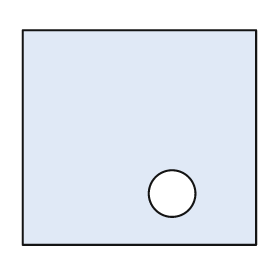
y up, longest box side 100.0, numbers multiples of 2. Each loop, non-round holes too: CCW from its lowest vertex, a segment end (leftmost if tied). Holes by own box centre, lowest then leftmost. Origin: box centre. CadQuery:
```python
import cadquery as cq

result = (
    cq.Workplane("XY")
    .moveTo(-50.0, -46.0)
    .lineTo(50.0, -46.0)
    .lineTo(50.0, 46.0)
    .lineTo(-50.0, 46.0)
    .close()
    .moveTo(14.0, -24.0)
    .circle(10.0)
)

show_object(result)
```